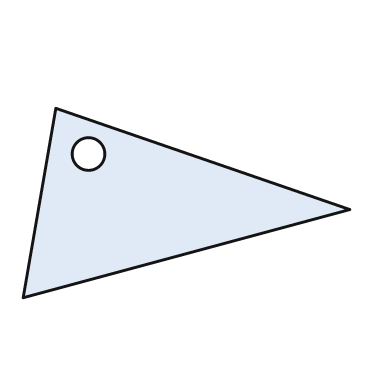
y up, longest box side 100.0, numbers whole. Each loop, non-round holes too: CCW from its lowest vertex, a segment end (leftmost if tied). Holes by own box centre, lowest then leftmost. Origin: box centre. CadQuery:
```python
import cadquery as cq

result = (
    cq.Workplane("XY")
    .moveTo(-50.0, -29.0)
    .lineTo(50.0, -2.0)
    .lineTo(-40.0, 29.0)
    .close()
    .moveTo(-30.0, 15.0)
    .circle(5.0)
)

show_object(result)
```